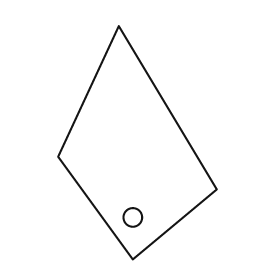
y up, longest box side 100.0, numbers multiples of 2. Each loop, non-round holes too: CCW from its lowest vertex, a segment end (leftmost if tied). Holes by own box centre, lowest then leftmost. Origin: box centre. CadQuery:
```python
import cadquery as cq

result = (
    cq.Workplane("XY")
    .moveTo(-2.0, -50.0)
    .lineTo(34.0, -20.0)
    .lineTo(-8.0, 50.0)
    .lineTo(-34.0, -6.0)
    .close()
    .moveTo(-2.0, -32.0)
    .circle(4.0)
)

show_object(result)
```